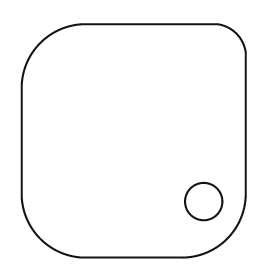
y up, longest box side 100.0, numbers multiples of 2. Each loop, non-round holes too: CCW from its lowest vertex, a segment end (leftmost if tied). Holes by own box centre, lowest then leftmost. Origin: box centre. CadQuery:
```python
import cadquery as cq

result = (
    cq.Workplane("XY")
    .moveTo(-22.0, -50.0)
    .lineTo(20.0, -50.0)
    .threePointArc((40.0, -42.0), (48.0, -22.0))
    .lineTo(48.0, 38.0)
    .threePointArc((44.0, 46.0), (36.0, 50.0))
    .lineTo(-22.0, 50.0)
    .threePointArc((-40.0, 42.0), (-48.0, 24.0))
    .lineTo(-48.0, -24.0)
    .threePointArc((-40.0, -42.0), (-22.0, -50.0))
    .close()
    .moveTo(30.0, -26.0)
    .circle(8.0)
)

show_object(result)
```